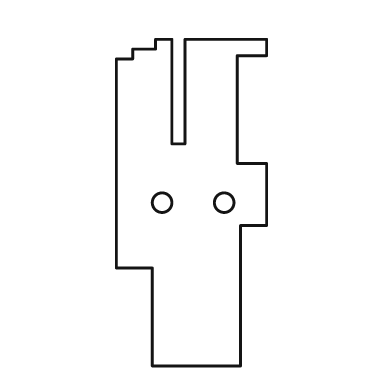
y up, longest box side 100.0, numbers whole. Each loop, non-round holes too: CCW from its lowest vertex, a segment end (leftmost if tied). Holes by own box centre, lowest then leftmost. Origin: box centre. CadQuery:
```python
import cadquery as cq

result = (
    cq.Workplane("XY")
    .moveTo(-12.0, -50.0)
    .lineTo(15.0, -50.0)
    .lineTo(15.0, -7.0)
    .lineTo(23.0, -7.0)
    .lineTo(23.0, 12.0)
    .lineTo(14.0, 12.0)
    .lineTo(14.0, 45.0)
    .lineTo(23.0, 45.0)
    .lineTo(23.0, 50.0)
    .lineTo(-2.0, 50.0)
    .lineTo(-2.0, 18.0)
    .lineTo(-6.0, 18.0)
    .lineTo(-6.0, 50.0)
    .lineTo(-11.0, 50.0)
    .lineTo(-11.0, 47.0)
    .lineTo(-18.0, 47.0)
    .lineTo(-18.0, 44.0)
    .lineTo(-23.0, 44.0)
    .lineTo(-23.0, -20.0)
    .lineTo(-12.0, -20.0)
    .close()
    .moveTo(-9.0, 0.0)
    .circle(3.0)
    .moveTo(10.0, 0.0)
    .circle(3.0)
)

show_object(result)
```